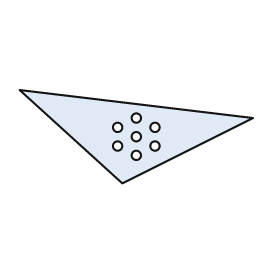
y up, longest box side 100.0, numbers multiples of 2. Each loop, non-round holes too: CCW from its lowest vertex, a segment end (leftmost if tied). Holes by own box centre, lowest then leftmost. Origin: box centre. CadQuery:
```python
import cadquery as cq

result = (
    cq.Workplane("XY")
    .moveTo(-6.0, -20.0)
    .lineTo(50.0, 8.0)
    .lineTo(-50.0, 20.0)
    .close()
    .moveTo(0.0, -8.0)
    .circle(2.0)
    .moveTo(-8.0, -4.0)
    .circle(2.0)
    .moveTo(8.0, -4.0)
    .circle(2.0)
    .moveTo(0.0, 0.0)
    .circle(2.0)
    .moveTo(-8.0, 4.0)
    .circle(2.0)
    .moveTo(8.0, 4.0)
    .circle(2.0)
    .moveTo(0.0, 8.0)
    .circle(2.0)
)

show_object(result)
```